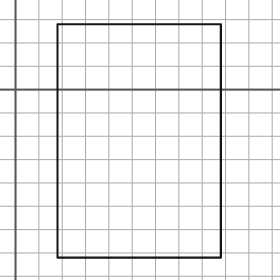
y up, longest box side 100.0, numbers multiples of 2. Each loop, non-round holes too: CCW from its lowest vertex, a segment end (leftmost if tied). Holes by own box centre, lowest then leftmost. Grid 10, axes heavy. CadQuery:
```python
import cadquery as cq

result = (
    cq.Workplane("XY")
    .moveTo(18.0, -72.0)
    .lineTo(88.0, -72.0)
    .lineTo(88.0, 28.0)
    .lineTo(18.0, 28.0)
    .close()
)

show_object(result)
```